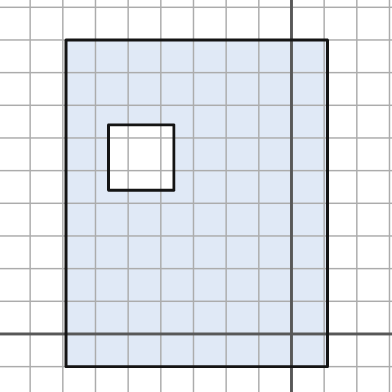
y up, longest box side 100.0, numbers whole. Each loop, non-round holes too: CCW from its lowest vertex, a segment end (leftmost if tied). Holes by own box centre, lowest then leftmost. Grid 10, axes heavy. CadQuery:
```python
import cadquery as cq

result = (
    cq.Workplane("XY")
    .moveTo(-69.0, -10.0)
    .lineTo(11.0, -10.0)
    .lineTo(11.0, 90.0)
    .lineTo(-69.0, 90.0)
    .close()
    .moveTo(-56.0, 44.0)
    .lineTo(-36.0, 44.0)
    .lineTo(-36.0, 64.0)
    .lineTo(-56.0, 64.0)
    .close()
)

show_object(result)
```